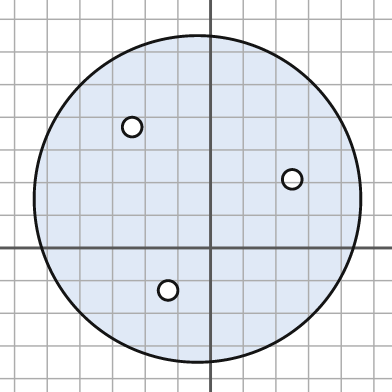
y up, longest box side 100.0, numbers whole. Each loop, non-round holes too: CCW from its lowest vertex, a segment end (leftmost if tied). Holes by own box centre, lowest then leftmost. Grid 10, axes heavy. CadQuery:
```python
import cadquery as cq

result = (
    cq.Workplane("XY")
    .moveTo(-4.0, 15.0)
    .circle(50.0)
    .moveTo(-13.0, -13.0)
    .circle(3.0)
    .moveTo(25.0, 21.0)
    .circle(3.0)
    .moveTo(-24.0, 37.0)
    .circle(3.0)
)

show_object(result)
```